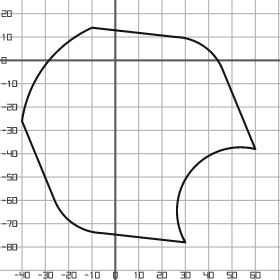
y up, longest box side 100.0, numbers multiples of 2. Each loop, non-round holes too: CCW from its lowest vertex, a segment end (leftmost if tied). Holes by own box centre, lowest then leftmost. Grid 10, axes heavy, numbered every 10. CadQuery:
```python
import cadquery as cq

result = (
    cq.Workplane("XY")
    .moveTo(30.0, -78.0)
    .threePointArc((32.0, -48.0), (60.0, -38.0))
    .lineTo(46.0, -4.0)
    .threePointArc((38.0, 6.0), (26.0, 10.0))
    .lineTo(-10.0, 14.0)
    .threePointArc((-30.0, -2.0), (-40.0, -26.0))
    .lineTo(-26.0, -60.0)
    .threePointArc((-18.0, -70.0), (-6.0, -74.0))
    .close()
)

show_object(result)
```